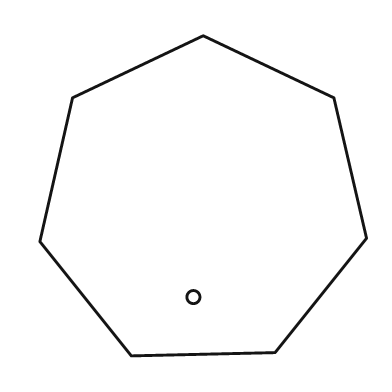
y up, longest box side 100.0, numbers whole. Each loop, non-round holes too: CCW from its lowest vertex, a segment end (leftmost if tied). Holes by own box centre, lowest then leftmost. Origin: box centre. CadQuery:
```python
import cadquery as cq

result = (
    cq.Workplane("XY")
    .moveTo(-22.0, -49.0)
    .lineTo(22.0, -48.0)
    .lineTo(50.0, -13.0)
    .lineTo(40.0, 30.0)
    .lineTo(0.0, 49.0)
    .lineTo(-40.0, 30.0)
    .lineTo(-50.0, -14.0)
    .close()
    .moveTo(-3.0, -31.0)
    .circle(2.0)
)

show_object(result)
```